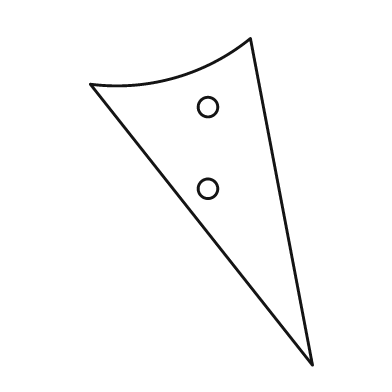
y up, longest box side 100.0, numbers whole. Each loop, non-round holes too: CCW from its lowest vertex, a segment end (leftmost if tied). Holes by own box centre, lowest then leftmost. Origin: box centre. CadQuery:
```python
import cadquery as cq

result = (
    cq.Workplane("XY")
    .moveTo(34.0, -50.0)
    .lineTo(15.0, 50.0)
    .threePointArc((-8.0, 38.0), (-34.0, 36.0))
    .close()
    .moveTo(2.0, 4.0)
    .circle(3.0)
    .moveTo(2.0, 29.0)
    .circle(3.0)
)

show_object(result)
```